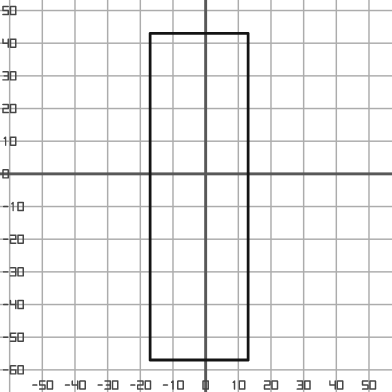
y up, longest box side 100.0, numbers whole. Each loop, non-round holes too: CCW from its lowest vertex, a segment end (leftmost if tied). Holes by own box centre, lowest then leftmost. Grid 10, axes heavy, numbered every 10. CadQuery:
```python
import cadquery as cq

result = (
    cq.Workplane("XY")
    .moveTo(-17.0, -57.0)
    .lineTo(13.0, -57.0)
    .lineTo(13.0, 43.0)
    .lineTo(-17.0, 43.0)
    .close()
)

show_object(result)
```